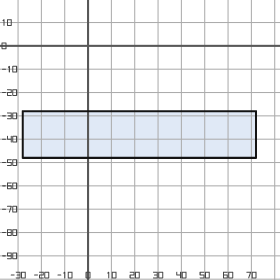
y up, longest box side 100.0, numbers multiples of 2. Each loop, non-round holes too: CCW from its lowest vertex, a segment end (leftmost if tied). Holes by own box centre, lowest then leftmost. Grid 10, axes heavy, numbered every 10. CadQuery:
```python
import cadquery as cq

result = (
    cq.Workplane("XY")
    .moveTo(-28.0, -48.0)
    .lineTo(72.0, -48.0)
    .lineTo(72.0, -28.0)
    .lineTo(-28.0, -28.0)
    .close()
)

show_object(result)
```